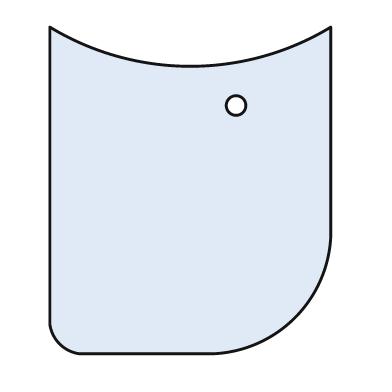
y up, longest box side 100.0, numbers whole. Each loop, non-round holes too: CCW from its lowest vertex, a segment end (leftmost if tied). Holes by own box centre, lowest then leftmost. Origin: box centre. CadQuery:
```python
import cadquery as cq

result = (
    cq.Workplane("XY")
    .moveTo(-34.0, -50.0)
    .lineTo(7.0, -50.0)
    .threePointArc((32.0, -39.0), (43.0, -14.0))
    .lineTo(43.0, 50.0)
    .threePointArc((0.0, 38.0), (-43.0, 50.0))
    .lineTo(-43.0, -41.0)
    .threePointArc((-40.0, -47.0), (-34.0, -50.0))
    .close()
    .moveTo(14.0, 26.0)
    .circle(3.0)
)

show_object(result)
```